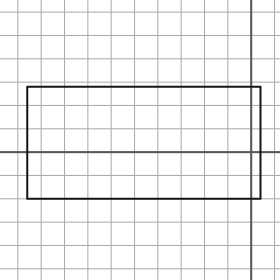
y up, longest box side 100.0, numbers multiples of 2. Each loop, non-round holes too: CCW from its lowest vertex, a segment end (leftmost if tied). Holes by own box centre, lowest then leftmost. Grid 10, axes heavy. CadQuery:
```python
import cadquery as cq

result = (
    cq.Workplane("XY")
    .moveTo(-96.0, -20.0)
    .lineTo(4.0, -20.0)
    .lineTo(4.0, 28.0)
    .lineTo(-96.0, 28.0)
    .close()
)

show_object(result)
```